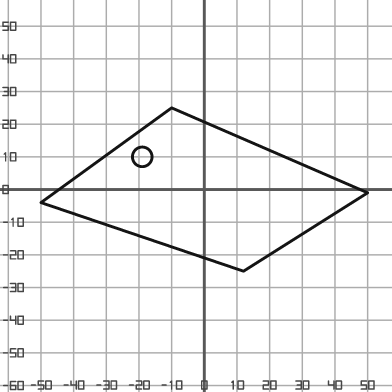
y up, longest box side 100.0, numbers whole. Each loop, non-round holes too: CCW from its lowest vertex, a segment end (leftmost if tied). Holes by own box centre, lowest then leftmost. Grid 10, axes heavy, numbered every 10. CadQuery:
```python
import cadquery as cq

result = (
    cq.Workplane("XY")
    .moveTo(12.0, -25.0)
    .lineTo(50.0, -1.0)
    .lineTo(-10.0, 25.0)
    .lineTo(-50.0, -4.0)
    .close()
    .moveTo(-19.0, 10.0)
    .circle(3.0)
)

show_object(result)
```